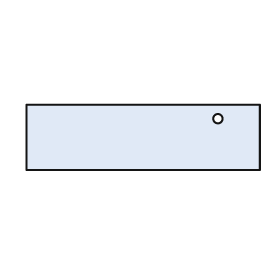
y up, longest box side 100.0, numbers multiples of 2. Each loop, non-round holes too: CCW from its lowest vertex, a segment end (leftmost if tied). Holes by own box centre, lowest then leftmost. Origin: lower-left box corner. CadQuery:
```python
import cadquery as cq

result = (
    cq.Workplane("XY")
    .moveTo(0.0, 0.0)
    .lineTo(100.0, 0.0)
    .lineTo(100.0, 28.0)
    .lineTo(0.0, 28.0)
    .close()
    .moveTo(82.0, 22.0)
    .circle(2.0)
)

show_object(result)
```